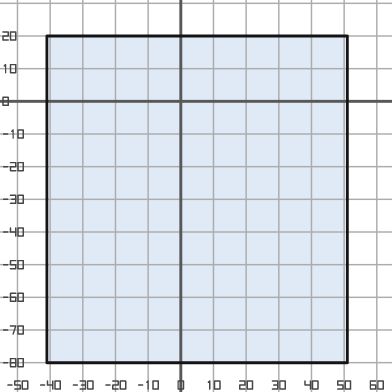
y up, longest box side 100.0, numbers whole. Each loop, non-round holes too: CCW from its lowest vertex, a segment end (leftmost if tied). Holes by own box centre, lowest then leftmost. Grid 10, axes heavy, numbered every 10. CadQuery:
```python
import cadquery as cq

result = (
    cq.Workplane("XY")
    .moveTo(-41.0, -80.0)
    .lineTo(51.0, -80.0)
    .lineTo(51.0, 20.0)
    .lineTo(-41.0, 20.0)
    .close()
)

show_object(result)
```